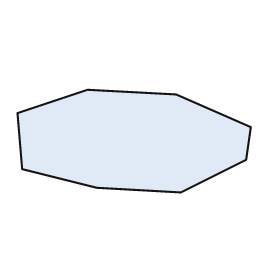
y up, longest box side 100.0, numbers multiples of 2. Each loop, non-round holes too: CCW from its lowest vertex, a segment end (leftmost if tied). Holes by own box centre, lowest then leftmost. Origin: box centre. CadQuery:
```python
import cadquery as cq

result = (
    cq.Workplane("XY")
    .moveTo(20.0, -22.0)
    .lineTo(48.0, -8.0)
    .lineTo(50.0, 6.0)
    .lineTo(18.0, 20.0)
    .lineTo(-20.0, 22.0)
    .lineTo(-50.0, 12.0)
    .lineTo(-48.0, -12.0)
    .lineTo(-16.0, -20.0)
    .close()
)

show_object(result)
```